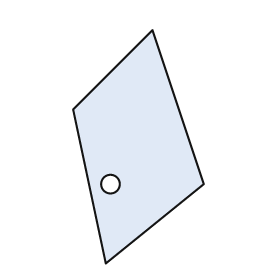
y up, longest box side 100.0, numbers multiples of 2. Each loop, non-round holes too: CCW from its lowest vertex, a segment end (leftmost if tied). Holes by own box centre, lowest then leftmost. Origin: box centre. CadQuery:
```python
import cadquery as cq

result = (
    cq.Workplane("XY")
    .moveTo(-14.0, -50.0)
    .lineTo(28.0, -16.0)
    .lineTo(6.0, 50.0)
    .lineTo(-28.0, 16.0)
    .close()
    .moveTo(-12.0, -16.0)
    .circle(4.0)
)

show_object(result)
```